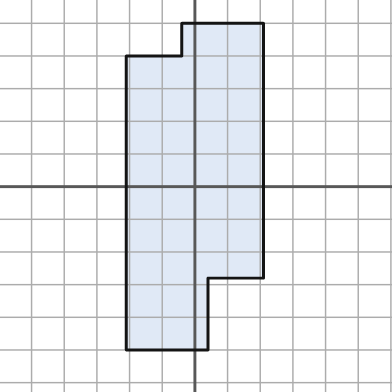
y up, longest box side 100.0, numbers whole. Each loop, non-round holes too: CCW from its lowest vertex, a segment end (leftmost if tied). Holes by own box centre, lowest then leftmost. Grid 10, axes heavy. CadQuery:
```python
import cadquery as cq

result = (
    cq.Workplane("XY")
    .moveTo(-21.0, -50.0)
    .lineTo(4.0, -50.0)
    .lineTo(4.0, -28.0)
    .lineTo(21.0, -28.0)
    .lineTo(21.0, 50.0)
    .lineTo(-4.0, 50.0)
    .lineTo(-4.0, 40.0)
    .lineTo(-21.0, 40.0)
    .close()
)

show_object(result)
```